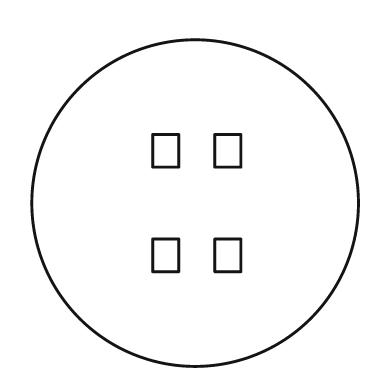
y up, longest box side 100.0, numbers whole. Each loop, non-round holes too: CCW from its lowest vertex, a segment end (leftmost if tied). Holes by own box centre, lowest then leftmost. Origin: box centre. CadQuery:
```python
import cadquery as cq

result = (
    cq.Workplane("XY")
    .moveTo(0.0, 0.0)
    .circle(50.0)
    .moveTo(-13.0, -21.0)
    .lineTo(-5.0, -21.0)
    .lineTo(-5.0, -11.0)
    .lineTo(-13.0, -11.0)
    .close()
    .moveTo(6.0, -21.0)
    .lineTo(14.0, -21.0)
    .lineTo(14.0, -11.0)
    .lineTo(6.0, -11.0)
    .close()
    .moveTo(-13.0, 11.0)
    .lineTo(-5.0, 11.0)
    .lineTo(-5.0, 21.0)
    .lineTo(-13.0, 21.0)
    .close()
    .moveTo(6.0, 11.0)
    .lineTo(14.0, 11.0)
    .lineTo(14.0, 21.0)
    .lineTo(6.0, 21.0)
    .close()
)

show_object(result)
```